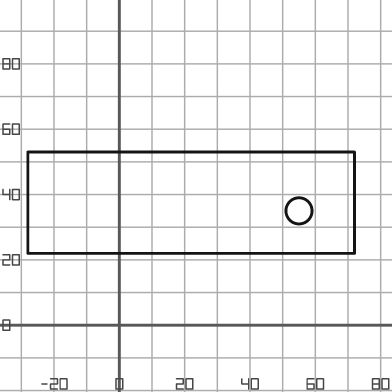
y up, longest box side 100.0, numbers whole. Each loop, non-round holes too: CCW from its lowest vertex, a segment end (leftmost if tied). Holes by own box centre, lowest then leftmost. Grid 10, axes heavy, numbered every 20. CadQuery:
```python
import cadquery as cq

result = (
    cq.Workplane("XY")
    .moveTo(-28.0, 22.0)
    .lineTo(72.0, 22.0)
    .lineTo(72.0, 53.0)
    .lineTo(-28.0, 53.0)
    .close()
    .moveTo(55.0, 35.0)
    .circle(4.0)
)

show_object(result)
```